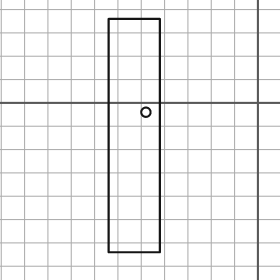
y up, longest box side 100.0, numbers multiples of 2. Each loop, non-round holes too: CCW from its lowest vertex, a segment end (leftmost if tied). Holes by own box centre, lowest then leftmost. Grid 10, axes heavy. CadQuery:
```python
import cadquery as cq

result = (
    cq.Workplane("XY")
    .moveTo(-64.0, -64.0)
    .lineTo(-42.0, -64.0)
    .lineTo(-42.0, 36.0)
    .lineTo(-64.0, 36.0)
    .close()
    .moveTo(-48.0, -4.0)
    .circle(2.0)
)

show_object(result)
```